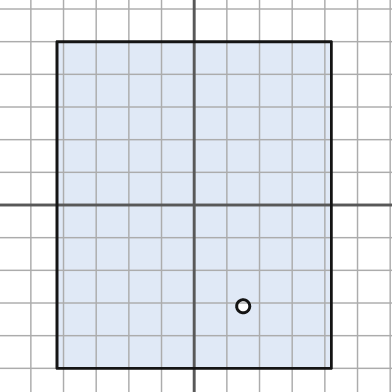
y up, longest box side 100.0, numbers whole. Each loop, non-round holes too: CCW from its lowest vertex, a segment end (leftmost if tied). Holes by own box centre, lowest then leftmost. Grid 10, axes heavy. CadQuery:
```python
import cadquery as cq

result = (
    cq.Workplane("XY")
    .moveTo(-42.0, -50.0)
    .lineTo(42.0, -50.0)
    .lineTo(42.0, 50.0)
    .lineTo(-42.0, 50.0)
    .close()
    .moveTo(15.0, -31.0)
    .circle(2.0)
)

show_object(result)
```